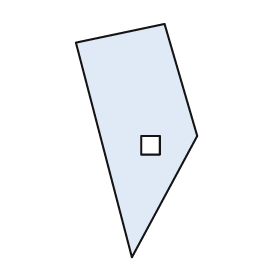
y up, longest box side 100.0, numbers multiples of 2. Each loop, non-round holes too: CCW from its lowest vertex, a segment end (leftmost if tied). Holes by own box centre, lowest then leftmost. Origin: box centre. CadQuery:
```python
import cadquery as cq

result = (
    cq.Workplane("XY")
    .moveTo(-2.0, -50.0)
    .lineTo(26.0, 2.0)
    .lineTo(12.0, 50.0)
    .lineTo(-26.0, 42.0)
    .close()
    .moveTo(2.0, -6.0)
    .lineTo(10.0, -6.0)
    .lineTo(10.0, 2.0)
    .lineTo(2.0, 2.0)
    .close()
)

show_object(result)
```